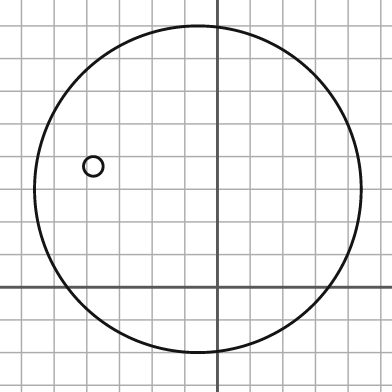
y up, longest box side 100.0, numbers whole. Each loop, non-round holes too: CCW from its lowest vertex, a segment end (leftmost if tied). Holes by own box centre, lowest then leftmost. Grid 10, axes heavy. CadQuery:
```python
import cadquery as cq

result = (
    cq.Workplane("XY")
    .moveTo(-6.0, 30.0)
    .circle(50.0)
    .moveTo(-38.0, 37.0)
    .circle(3.0)
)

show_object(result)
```